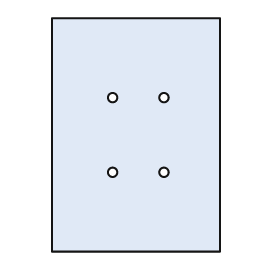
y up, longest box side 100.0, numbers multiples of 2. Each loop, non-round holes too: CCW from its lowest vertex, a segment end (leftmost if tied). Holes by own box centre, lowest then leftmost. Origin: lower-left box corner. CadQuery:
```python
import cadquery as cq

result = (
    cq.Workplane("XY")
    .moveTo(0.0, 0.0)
    .lineTo(72.0, 0.0)
    .lineTo(72.0, 100.0)
    .lineTo(0.0, 100.0)
    .close()
    .moveTo(26.0, 34.0)
    .circle(2.0)
    .moveTo(48.0, 34.0)
    .circle(2.0)
    .moveTo(26.0, 66.0)
    .circle(2.0)
    .moveTo(48.0, 66.0)
    .circle(2.0)
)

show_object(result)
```